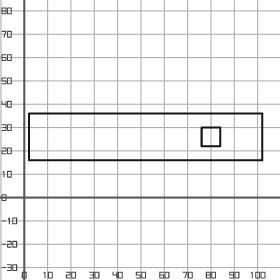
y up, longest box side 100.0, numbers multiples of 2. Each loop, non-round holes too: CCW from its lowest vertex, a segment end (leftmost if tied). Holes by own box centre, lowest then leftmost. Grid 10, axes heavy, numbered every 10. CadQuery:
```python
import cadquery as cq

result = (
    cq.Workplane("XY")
    .moveTo(2.0, 16.0)
    .lineTo(102.0, 16.0)
    .lineTo(102.0, 36.0)
    .lineTo(2.0, 36.0)
    .close()
    .moveTo(76.0, 22.0)
    .lineTo(84.0, 22.0)
    .lineTo(84.0, 30.0)
    .lineTo(76.0, 30.0)
    .close()
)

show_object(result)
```